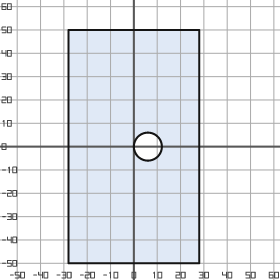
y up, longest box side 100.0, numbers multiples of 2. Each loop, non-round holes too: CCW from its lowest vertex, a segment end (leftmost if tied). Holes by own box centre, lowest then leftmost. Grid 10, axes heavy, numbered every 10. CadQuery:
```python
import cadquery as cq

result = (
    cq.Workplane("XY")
    .moveTo(-28.0, -50.0)
    .lineTo(28.0, -50.0)
    .lineTo(28.0, 50.0)
    .lineTo(-28.0, 50.0)
    .close()
    .moveTo(6.0, 0.0)
    .circle(6.0)
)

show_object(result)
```